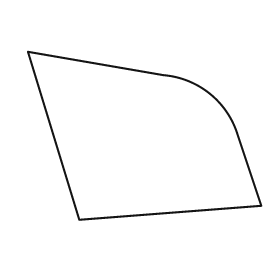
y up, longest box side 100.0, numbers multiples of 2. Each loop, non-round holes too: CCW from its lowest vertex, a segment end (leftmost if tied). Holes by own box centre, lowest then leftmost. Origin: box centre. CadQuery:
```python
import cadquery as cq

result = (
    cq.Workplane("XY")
    .moveTo(-28.0, -36.0)
    .lineTo(50.0, -30.0)
    .lineTo(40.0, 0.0)
    .threePointArc((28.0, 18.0), (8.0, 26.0))
    .lineTo(-50.0, 36.0)
    .close()
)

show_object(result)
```